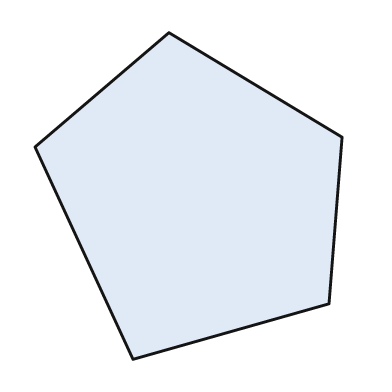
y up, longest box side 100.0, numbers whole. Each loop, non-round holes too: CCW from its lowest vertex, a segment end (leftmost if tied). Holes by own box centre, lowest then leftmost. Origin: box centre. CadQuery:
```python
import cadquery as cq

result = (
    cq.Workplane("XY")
    .moveTo(-17.0, -50.0)
    .lineTo(43.0, -33.0)
    .lineTo(47.0, 18.0)
    .lineTo(-6.0, 50.0)
    .lineTo(-47.0, 15.0)
    .close()
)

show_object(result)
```